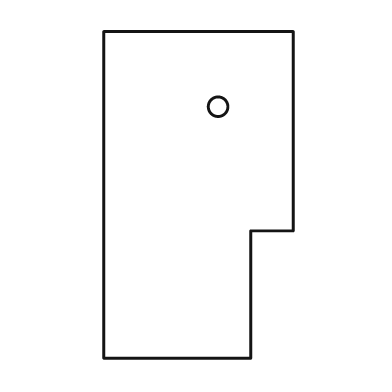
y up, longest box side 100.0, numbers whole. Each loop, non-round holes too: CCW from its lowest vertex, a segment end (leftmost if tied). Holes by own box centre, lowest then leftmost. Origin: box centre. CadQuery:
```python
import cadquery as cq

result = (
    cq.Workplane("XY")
    .moveTo(-29.0, -50.0)
    .lineTo(16.0, -50.0)
    .lineTo(16.0, -11.0)
    .lineTo(29.0, -11.0)
    .lineTo(29.0, 50.0)
    .lineTo(-29.0, 50.0)
    .close()
    .moveTo(6.0, 27.0)
    .circle(3.0)
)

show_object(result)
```